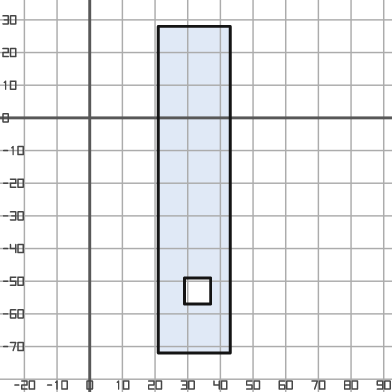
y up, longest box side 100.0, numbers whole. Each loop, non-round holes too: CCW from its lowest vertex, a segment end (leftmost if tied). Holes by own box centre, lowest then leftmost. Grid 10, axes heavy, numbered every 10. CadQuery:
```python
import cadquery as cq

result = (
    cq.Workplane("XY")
    .moveTo(21.0, -72.0)
    .lineTo(43.0, -72.0)
    .lineTo(43.0, 28.0)
    .lineTo(21.0, 28.0)
    .close()
    .moveTo(29.0, -57.0)
    .lineTo(37.0, -57.0)
    .lineTo(37.0, -49.0)
    .lineTo(29.0, -49.0)
    .close()
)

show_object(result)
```